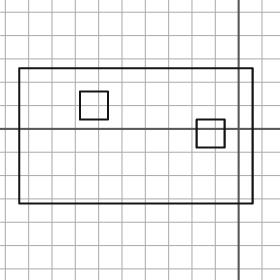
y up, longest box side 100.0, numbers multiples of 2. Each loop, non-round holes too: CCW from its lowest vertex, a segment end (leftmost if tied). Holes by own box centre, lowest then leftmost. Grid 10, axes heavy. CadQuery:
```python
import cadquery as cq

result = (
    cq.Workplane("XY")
    .moveTo(-94.0, -32.0)
    .lineTo(6.0, -32.0)
    .lineTo(6.0, 26.0)
    .lineTo(-94.0, 26.0)
    .close()
    .moveTo(-18.0, -8.0)
    .lineTo(-6.0, -8.0)
    .lineTo(-6.0, 4.0)
    .lineTo(-18.0, 4.0)
    .close()
    .moveTo(-68.0, 4.0)
    .lineTo(-56.0, 4.0)
    .lineTo(-56.0, 16.0)
    .lineTo(-68.0, 16.0)
    .close()
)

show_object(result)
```